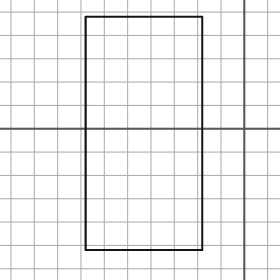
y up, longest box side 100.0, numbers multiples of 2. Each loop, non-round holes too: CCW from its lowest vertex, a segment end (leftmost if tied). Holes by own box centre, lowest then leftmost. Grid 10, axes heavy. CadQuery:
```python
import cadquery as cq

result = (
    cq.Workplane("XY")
    .moveTo(-68.0, -52.0)
    .lineTo(-18.0, -52.0)
    .lineTo(-18.0, 48.0)
    .lineTo(-68.0, 48.0)
    .close()
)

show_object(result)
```